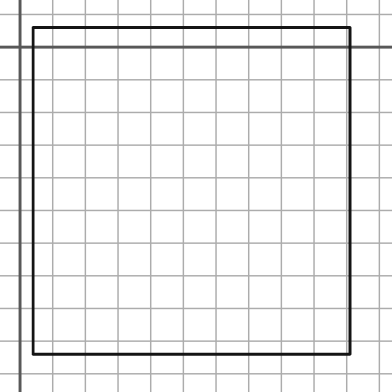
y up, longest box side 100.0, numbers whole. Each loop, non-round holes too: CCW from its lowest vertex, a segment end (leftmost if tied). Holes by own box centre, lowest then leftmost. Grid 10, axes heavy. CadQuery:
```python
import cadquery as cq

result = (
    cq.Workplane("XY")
    .moveTo(4.0, -94.0)
    .lineTo(101.0, -94.0)
    .lineTo(101.0, 6.0)
    .lineTo(4.0, 6.0)
    .close()
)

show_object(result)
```